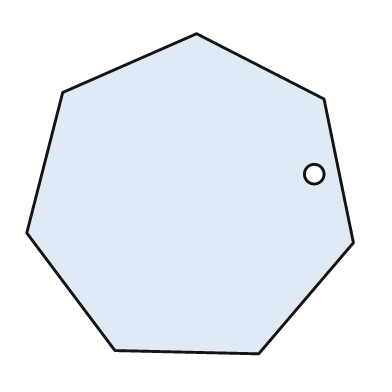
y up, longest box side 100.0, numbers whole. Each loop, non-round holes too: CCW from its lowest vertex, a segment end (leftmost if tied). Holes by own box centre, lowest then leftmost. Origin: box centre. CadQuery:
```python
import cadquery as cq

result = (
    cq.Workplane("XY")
    .moveTo(21.0, -49.0)
    .lineTo(50.0, -15.0)
    .lineTo(41.0, 29.0)
    .lineTo(2.0, 49.0)
    .lineTo(-39.0, 31.0)
    .lineTo(-50.0, -12.0)
    .lineTo(-23.0, -48.0)
    .close()
    .moveTo(38.0, 6.0)
    .circle(3.0)
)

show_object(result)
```